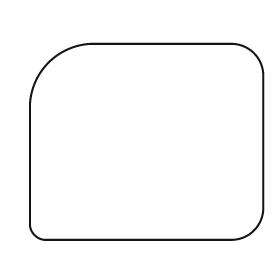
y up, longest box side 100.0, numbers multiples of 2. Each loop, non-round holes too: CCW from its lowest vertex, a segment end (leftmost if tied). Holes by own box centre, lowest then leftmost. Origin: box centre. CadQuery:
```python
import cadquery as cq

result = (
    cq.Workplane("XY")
    .moveTo(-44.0, -42.0)
    .lineTo(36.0, -42.0)
    .threePointArc((46.0, -38.0), (50.0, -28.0))
    .lineTo(50.0, 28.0)
    .threePointArc((46.0, 38.0), (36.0, 42.0))
    .lineTo(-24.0, 42.0)
    .threePointArc((-42.0, 34.0), (-50.0, 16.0))
    .lineTo(-50.0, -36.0)
    .threePointArc((-48.0, -40.0), (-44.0, -42.0))
    .close()
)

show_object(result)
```